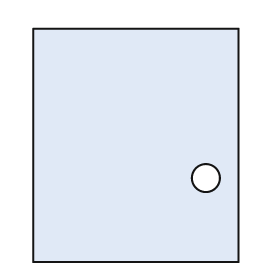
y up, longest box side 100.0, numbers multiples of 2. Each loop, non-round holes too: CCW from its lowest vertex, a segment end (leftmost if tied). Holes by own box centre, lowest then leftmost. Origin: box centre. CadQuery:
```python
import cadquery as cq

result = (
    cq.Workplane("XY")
    .moveTo(-44.0, -50.0)
    .lineTo(44.0, -50.0)
    .lineTo(44.0, 50.0)
    .lineTo(-44.0, 50.0)
    .close()
    .moveTo(30.0, -14.0)
    .circle(6.0)
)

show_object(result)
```